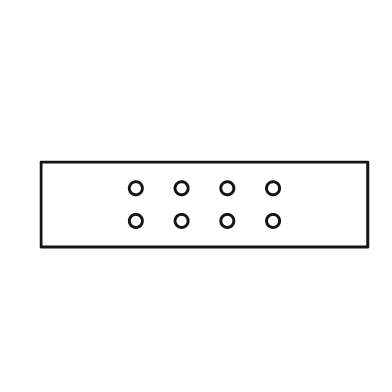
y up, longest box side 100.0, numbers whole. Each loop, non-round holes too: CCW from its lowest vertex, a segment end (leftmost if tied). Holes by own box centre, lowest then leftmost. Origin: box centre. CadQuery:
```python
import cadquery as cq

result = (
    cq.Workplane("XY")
    .moveTo(-50.0, -13.0)
    .lineTo(50.0, -13.0)
    .lineTo(50.0, 13.0)
    .lineTo(-50.0, 13.0)
    .close()
    .moveTo(-21.0, -5.0)
    .circle(2.0)
    .moveTo(-7.0, -5.0)
    .circle(2.0)
    .moveTo(7.0, -5.0)
    .circle(2.0)
    .moveTo(21.0, -5.0)
    .circle(2.0)
    .moveTo(-21.0, 5.0)
    .circle(2.0)
    .moveTo(-7.0, 5.0)
    .circle(2.0)
    .moveTo(7.0, 5.0)
    .circle(2.0)
    .moveTo(21.0, 5.0)
    .circle(2.0)
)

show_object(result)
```